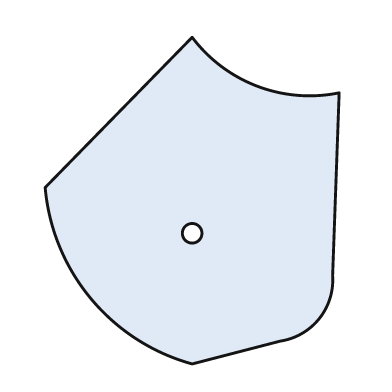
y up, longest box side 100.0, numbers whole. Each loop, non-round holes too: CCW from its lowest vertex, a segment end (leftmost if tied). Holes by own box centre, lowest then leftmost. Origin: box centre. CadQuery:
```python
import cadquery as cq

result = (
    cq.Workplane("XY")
    .moveTo(0.0, -50.0)
    .lineTo(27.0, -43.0)
    .threePointArc((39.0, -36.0), (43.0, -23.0))
    .lineTo(45.0, 33.0)
    .threePointArc((20.0, 35.0), (0.0, 50.0))
    .lineTo(-45.0, 4.0)
    .threePointArc((-31.0, -30.0), (0.0, -50.0))
    .close()
    .moveTo(0.0, -10.0)
    .circle(3.0)
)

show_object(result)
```